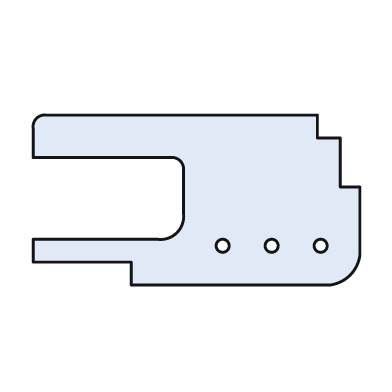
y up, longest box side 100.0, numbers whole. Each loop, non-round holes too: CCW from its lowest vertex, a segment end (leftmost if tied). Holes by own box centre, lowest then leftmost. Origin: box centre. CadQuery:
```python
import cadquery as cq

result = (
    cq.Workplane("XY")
    .moveTo(-20.0, -26.0)
    .lineTo(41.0, -26.0)
    .threePointArc((47.0, -23.0), (50.0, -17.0))
    .lineTo(50.0, 4.0)
    .lineTo(44.0, 4.0)
    .lineTo(44.0, 19.0)
    .lineTo(37.0, 19.0)
    .lineTo(37.0, 26.0)
    .lineTo(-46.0, 26.0)
    .threePointArc((-49.0, 25.0), (-50.0, 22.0))
    .lineTo(-50.0, 13.0)
    .lineTo(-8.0, 13.0)
    .threePointArc((-5.0, 12.0), (-4.0, 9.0))
    .lineTo(-4.0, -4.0)
    .threePointArc((-6.0, -10.0), (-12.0, -12.0))
    .lineTo(-50.0, -12.0)
    .lineTo(-50.0, -19.0)
    .lineTo(-20.0, -19.0)
    .close()
    .moveTo(8.0, -14.0)
    .circle(2.0)
    .moveTo(23.0, -14.0)
    .circle(2.0)
    .moveTo(38.0, -14.0)
    .circle(2.0)
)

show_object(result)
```